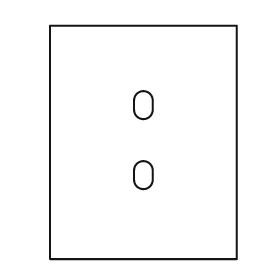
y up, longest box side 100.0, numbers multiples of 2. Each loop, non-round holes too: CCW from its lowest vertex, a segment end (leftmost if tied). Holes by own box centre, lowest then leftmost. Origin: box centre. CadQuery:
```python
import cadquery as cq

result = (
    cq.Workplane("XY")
    .moveTo(-40.0, -50.0)
    .lineTo(40.0, -50.0)
    .lineTo(40.0, 50.0)
    .lineTo(-40.0, 50.0)
    .close()
    .moveTo(-4.0, -16.0)
    .threePointArc((0.0, -20.0), (4.0, -16.0))
    .lineTo(4.0, -12.0)
    .threePointArc((0.0, -8.0), (-4.0, -12.0))
    .close()
    .moveTo(-4.0, 14.0)
    .threePointArc((0.0, 10.0), (4.0, 14.0))
    .lineTo(4.0, 18.0)
    .threePointArc((0.0, 22.0), (-4.0, 18.0))
    .close()
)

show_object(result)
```